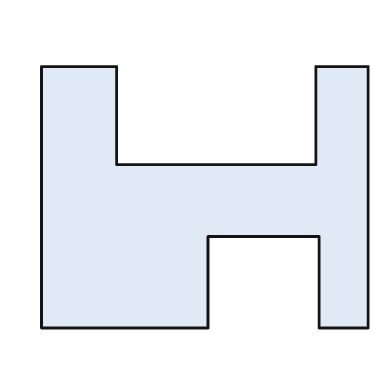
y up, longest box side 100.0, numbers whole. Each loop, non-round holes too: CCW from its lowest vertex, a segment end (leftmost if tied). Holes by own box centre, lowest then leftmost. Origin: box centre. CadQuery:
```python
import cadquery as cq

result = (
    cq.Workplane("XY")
    .moveTo(-50.0, -40.0)
    .lineTo(1.0, -40.0)
    .lineTo(1.0, -12.0)
    .lineTo(35.0, -12.0)
    .lineTo(35.0, -40.0)
    .lineTo(50.0, -40.0)
    .lineTo(50.0, 40.0)
    .lineTo(34.0, 40.0)
    .lineTo(34.0, 10.0)
    .lineTo(-27.0, 10.0)
    .lineTo(-27.0, 40.0)
    .lineTo(-50.0, 40.0)
    .close()
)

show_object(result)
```